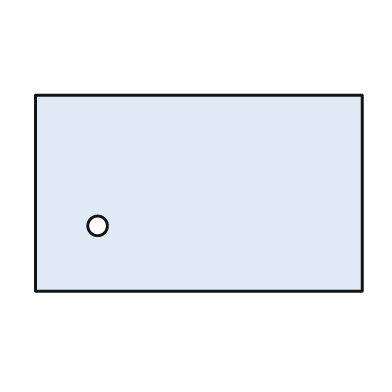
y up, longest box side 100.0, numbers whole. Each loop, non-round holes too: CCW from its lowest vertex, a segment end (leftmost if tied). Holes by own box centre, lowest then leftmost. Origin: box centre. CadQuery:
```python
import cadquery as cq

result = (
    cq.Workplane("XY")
    .moveTo(-50.0, -30.0)
    .lineTo(50.0, -30.0)
    .lineTo(50.0, 30.0)
    .lineTo(-50.0, 30.0)
    .close()
    .moveTo(-31.0, -10.0)
    .circle(3.0)
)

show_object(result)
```